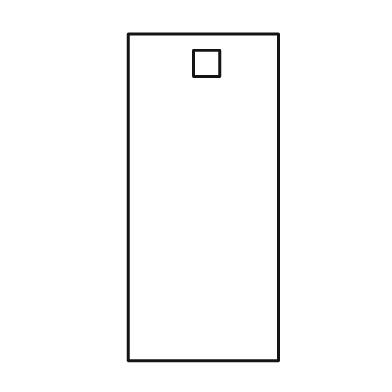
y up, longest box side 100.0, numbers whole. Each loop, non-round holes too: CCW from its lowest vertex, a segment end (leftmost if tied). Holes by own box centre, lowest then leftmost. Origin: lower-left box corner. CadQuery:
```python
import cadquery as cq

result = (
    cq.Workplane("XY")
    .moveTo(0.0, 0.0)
    .lineTo(46.0, 0.0)
    .lineTo(46.0, 100.0)
    .lineTo(0.0, 100.0)
    .close()
    .moveTo(20.0, 87.0)
    .lineTo(28.0, 87.0)
    .lineTo(28.0, 95.0)
    .lineTo(20.0, 95.0)
    .close()
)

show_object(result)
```